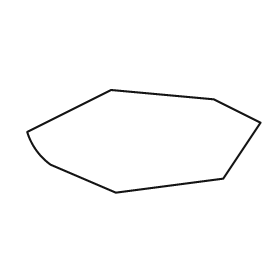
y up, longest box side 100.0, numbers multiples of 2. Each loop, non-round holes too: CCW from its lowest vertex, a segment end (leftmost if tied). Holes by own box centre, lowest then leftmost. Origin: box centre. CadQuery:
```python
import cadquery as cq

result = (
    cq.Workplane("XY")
    .moveTo(-12.0, -22.0)
    .lineTo(34.0, -16.0)
    .lineTo(50.0, 8.0)
    .lineTo(30.0, 18.0)
    .lineTo(-14.0, 22.0)
    .lineTo(-50.0, 4.0)
    .threePointArc((-46.0, -4.0), (-40.0, -10.0))
    .close()
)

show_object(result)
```